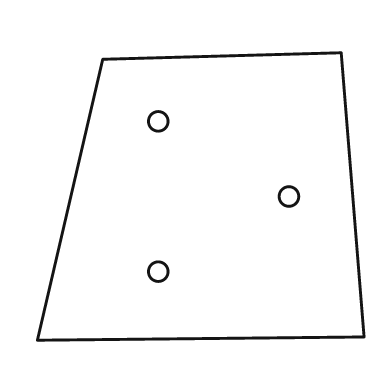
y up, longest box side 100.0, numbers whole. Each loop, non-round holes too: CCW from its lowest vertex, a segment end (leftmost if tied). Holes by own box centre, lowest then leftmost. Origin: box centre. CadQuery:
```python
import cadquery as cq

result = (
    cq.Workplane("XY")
    .moveTo(-50.0, -44.0)
    .lineTo(50.0, -43.0)
    .lineTo(43.0, 44.0)
    .lineTo(-30.0, 42.0)
    .close()
    .moveTo(-13.0, -23.0)
    .circle(3.0)
    .moveTo(27.0, 0.0)
    .circle(3.0)
    .moveTo(-13.0, 23.0)
    .circle(3.0)
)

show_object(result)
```